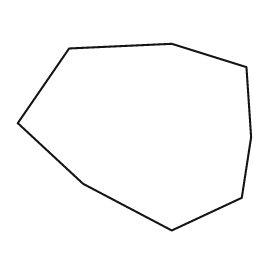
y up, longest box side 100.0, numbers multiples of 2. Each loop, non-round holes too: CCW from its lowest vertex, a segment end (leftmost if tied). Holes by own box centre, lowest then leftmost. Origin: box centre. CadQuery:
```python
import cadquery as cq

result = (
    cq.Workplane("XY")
    .moveTo(16.0, -40.0)
    .lineTo(46.0, -26.0)
    .lineTo(50.0, 0.0)
    .lineTo(48.0, 30.0)
    .lineTo(16.0, 40.0)
    .lineTo(-28.0, 38.0)
    .lineTo(-50.0, 6.0)
    .lineTo(-22.0, -20.0)
    .close()
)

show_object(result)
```